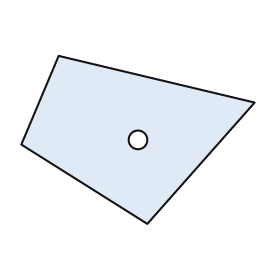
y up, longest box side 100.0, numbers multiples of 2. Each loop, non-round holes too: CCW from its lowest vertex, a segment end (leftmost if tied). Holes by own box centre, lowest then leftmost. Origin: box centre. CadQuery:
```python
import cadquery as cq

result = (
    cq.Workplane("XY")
    .moveTo(4.0, -36.0)
    .lineTo(50.0, 16.0)
    .lineTo(-34.0, 36.0)
    .lineTo(-50.0, -2.0)
    .close()
    .moveTo(0.0, 0.0)
    .circle(4.0)
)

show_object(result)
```